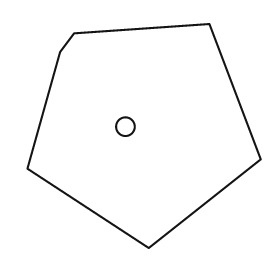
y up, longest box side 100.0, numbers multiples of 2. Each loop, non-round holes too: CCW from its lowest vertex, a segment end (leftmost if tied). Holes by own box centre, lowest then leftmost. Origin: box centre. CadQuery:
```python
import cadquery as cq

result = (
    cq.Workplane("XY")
    .moveTo(2.0, -48.0)
    .lineTo(50.0, -10.0)
    .lineTo(28.0, 48.0)
    .lineTo(-30.0, 44.0)
    .lineTo(-36.0, 36.0)
    .lineTo(-50.0, -14.0)
    .close()
    .moveTo(-8.0, 4.0)
    .circle(4.0)
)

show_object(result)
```